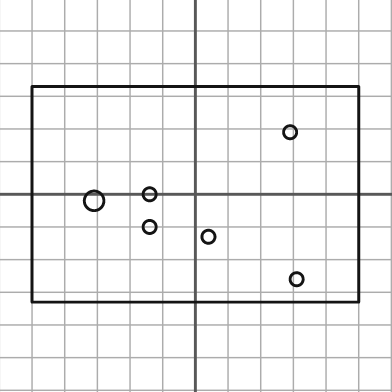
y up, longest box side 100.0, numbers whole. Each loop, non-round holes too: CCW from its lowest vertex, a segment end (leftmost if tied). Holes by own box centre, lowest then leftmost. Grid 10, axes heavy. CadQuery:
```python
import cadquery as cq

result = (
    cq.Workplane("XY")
    .moveTo(-50.0, -33.0)
    .lineTo(50.0, -33.0)
    .lineTo(50.0, 33.0)
    .lineTo(-50.0, 33.0)
    .close()
    .moveTo(31.0, -26.0)
    .circle(2.0)
    .moveTo(4.0, -13.0)
    .circle(2.0)
    .moveTo(-14.0, -10.0)
    .circle(2.0)
    .moveTo(-31.0, -2.0)
    .circle(3.0)
    .moveTo(-14.0, 0.0)
    .circle(2.0)
    .moveTo(29.0, 19.0)
    .circle(2.0)
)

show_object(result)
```